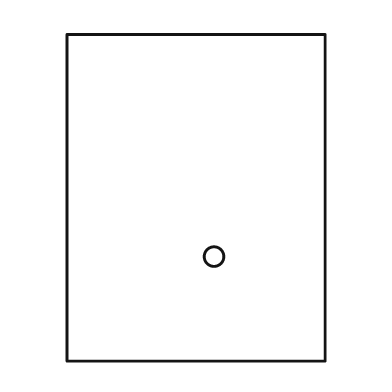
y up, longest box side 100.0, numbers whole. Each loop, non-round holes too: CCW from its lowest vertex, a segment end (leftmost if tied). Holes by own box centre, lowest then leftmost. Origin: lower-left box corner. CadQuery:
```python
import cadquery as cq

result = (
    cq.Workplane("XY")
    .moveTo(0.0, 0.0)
    .lineTo(79.0, 0.0)
    .lineTo(79.0, 100.0)
    .lineTo(0.0, 100.0)
    .close()
    .moveTo(45.0, 32.0)
    .circle(3.0)
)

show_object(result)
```